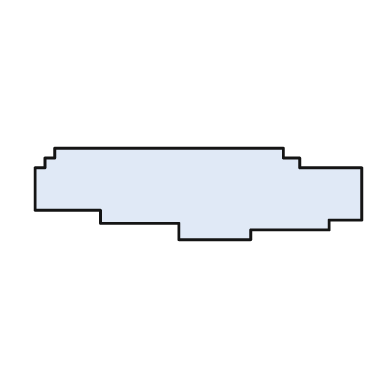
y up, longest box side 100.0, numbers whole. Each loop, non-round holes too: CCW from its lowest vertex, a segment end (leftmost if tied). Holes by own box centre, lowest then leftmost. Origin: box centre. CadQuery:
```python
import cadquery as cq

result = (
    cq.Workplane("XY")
    .moveTo(-6.0, -14.0)
    .lineTo(16.0, -14.0)
    .lineTo(16.0, -11.0)
    .lineTo(40.0, -11.0)
    .lineTo(40.0, -8.0)
    .lineTo(50.0, -8.0)
    .lineTo(50.0, 8.0)
    .lineTo(31.0, 8.0)
    .lineTo(31.0, 11.0)
    .lineTo(26.0, 11.0)
    .lineTo(26.0, 14.0)
    .lineTo(-44.0, 14.0)
    .lineTo(-44.0, 11.0)
    .lineTo(-47.0, 11.0)
    .lineTo(-47.0, 8.0)
    .lineTo(-50.0, 8.0)
    .lineTo(-50.0, -5.0)
    .lineTo(-30.0, -5.0)
    .lineTo(-30.0, -9.0)
    .lineTo(-6.0, -9.0)
    .close()
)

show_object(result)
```